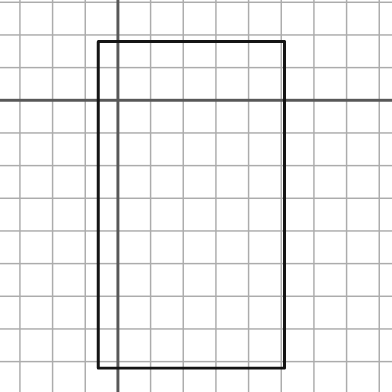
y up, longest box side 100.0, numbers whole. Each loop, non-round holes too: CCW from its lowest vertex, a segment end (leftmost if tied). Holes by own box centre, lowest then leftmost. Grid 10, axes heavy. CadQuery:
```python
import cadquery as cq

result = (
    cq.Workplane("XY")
    .moveTo(-6.0, -82.0)
    .lineTo(51.0, -82.0)
    .lineTo(51.0, 18.0)
    .lineTo(-6.0, 18.0)
    .close()
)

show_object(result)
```